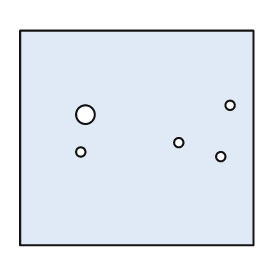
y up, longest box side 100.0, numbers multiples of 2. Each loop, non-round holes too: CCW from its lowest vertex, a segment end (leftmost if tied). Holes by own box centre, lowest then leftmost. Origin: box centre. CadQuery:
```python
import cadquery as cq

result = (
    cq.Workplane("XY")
    .moveTo(-50.0, -46.0)
    .lineTo(50.0, -46.0)
    .lineTo(50.0, 46.0)
    .lineTo(-50.0, 46.0)
    .close()
    .moveTo(36.0, -8.0)
    .circle(2.0)
    .moveTo(-24.0, -6.0)
    .circle(2.0)
    .moveTo(18.0, -2.0)
    .circle(2.0)
    .moveTo(-22.0, 10.0)
    .circle(4.0)
    .moveTo(40.0, 14.0)
    .circle(2.0)
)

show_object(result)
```